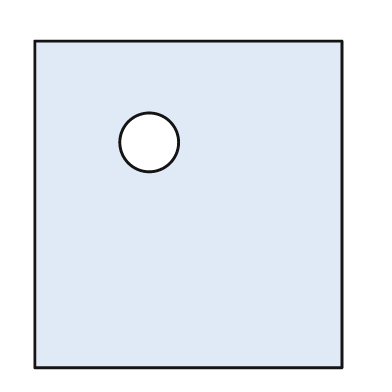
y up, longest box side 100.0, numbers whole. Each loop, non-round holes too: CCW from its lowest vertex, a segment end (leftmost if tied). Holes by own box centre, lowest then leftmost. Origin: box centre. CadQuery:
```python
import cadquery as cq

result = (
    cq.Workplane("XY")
    .moveTo(-47.0, -50.0)
    .lineTo(47.0, -50.0)
    .lineTo(47.0, 50.0)
    .lineTo(-47.0, 50.0)
    .close()
    .moveTo(-12.0, 19.0)
    .circle(9.0)
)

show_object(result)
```